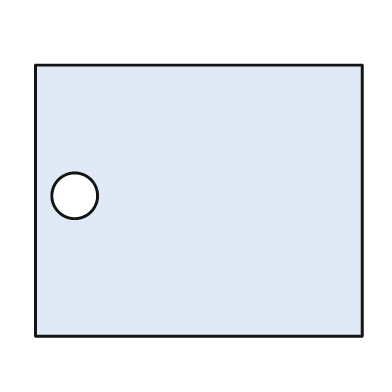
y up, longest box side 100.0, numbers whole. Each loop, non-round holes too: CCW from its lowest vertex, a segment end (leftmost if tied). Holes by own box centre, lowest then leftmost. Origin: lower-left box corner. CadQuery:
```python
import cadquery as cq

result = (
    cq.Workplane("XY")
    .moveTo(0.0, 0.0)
    .lineTo(100.0, 0.0)
    .lineTo(100.0, 83.0)
    .lineTo(0.0, 83.0)
    .close()
    .moveTo(12.0, 43.0)
    .circle(7.0)
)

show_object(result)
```